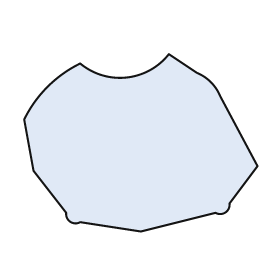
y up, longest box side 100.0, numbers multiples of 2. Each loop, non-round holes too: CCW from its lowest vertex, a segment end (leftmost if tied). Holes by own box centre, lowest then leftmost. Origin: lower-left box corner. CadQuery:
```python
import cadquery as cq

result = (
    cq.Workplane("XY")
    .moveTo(50.0, 0.0)
    .lineTo(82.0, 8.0)
    .threePointArc((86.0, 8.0), (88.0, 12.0))
    .lineTo(100.0, 28.0)
    .lineTo(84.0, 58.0)
    .threePointArc((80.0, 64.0), (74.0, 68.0))
    .lineTo(62.0, 76.0)
    .threePointArc((44.0, 66.0), (24.0, 72.0))
    .threePointArc((10.0, 62.0), (0.0, 48.0))
    .lineTo(4.0, 26.0)
    .lineTo(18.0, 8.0)
    .threePointArc((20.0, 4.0), (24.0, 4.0))
    .close()
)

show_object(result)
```